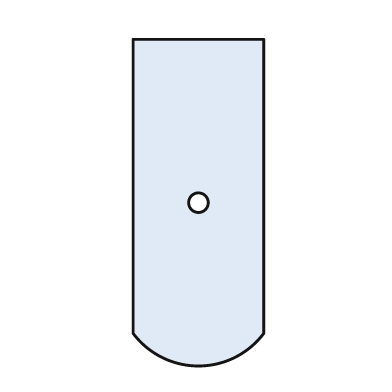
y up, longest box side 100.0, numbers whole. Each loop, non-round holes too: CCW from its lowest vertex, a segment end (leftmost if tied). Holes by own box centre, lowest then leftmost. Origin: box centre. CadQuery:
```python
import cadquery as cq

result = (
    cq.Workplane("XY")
    .moveTo(-20.0, -40.0)
    .threePointArc((0.0, -50.0), (20.0, -40.0))
    .lineTo(20.0, 50.0)
    .lineTo(-20.0, 50.0)
    .close()
    .moveTo(0.0, 0.0)
    .circle(3.0)
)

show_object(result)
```